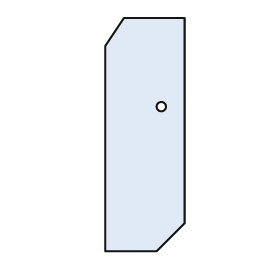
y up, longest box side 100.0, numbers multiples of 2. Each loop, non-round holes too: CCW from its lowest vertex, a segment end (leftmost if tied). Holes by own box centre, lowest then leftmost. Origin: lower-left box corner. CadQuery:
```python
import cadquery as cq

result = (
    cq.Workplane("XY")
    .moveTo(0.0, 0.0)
    .lineTo(22.0, 0.0)
    .lineTo(34.0, 12.0)
    .lineTo(34.0, 100.0)
    .lineTo(8.0, 100.0)
    .lineTo(0.0, 88.0)
    .close()
    .moveTo(24.0, 62.0)
    .circle(2.0)
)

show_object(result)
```